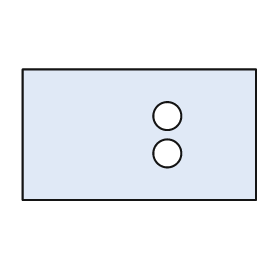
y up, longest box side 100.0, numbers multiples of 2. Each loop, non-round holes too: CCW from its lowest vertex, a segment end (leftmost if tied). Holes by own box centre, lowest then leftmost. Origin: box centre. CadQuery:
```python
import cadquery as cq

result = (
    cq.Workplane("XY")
    .moveTo(-50.0, -28.0)
    .lineTo(50.0, -28.0)
    .lineTo(50.0, 28.0)
    .lineTo(-50.0, 28.0)
    .close()
    .moveTo(12.0, -8.0)
    .circle(6.0)
    .moveTo(12.0, 8.0)
    .circle(6.0)
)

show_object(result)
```